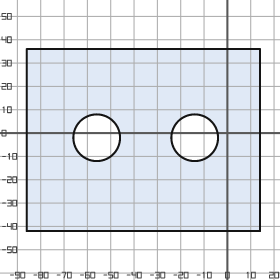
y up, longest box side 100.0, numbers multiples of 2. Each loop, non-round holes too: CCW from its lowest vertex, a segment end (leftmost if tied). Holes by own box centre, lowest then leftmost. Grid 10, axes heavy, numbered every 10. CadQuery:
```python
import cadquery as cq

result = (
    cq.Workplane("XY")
    .moveTo(-86.0, -42.0)
    .lineTo(14.0, -42.0)
    .lineTo(14.0, 36.0)
    .lineTo(-86.0, 36.0)
    .close()
    .moveTo(-56.0, -2.0)
    .circle(10.0)
    .moveTo(-14.0, -2.0)
    .circle(10.0)
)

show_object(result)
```